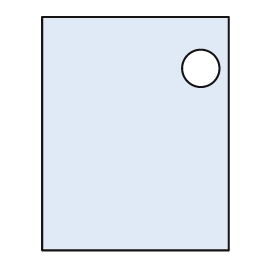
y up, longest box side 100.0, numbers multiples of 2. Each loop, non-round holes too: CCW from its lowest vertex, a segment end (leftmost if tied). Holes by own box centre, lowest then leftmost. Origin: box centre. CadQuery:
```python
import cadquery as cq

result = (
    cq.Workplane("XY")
    .moveTo(-40.0, -50.0)
    .lineTo(40.0, -50.0)
    .lineTo(40.0, 50.0)
    .lineTo(-40.0, 50.0)
    .close()
    .moveTo(28.0, 28.0)
    .circle(8.0)
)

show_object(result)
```